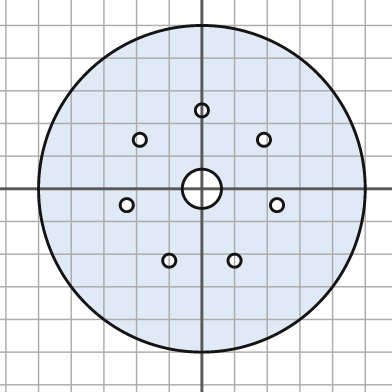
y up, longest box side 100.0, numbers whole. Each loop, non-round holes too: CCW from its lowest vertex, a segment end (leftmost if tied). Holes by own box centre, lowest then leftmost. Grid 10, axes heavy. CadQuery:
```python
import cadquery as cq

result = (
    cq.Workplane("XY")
    .moveTo(0.0, 0.0)
    .circle(50.0)
    .moveTo(-10.0, -22.0)
    .circle(2.0)
    .moveTo(10.0, -22.0)
    .circle(2.0)
    .moveTo(-23.0, -5.0)
    .circle(2.0)
    .moveTo(23.0, -5.0)
    .circle(2.0)
    .moveTo(0.0, 0.0)
    .circle(6.0)
    .moveTo(-19.0, 15.0)
    .circle(2.0)
    .moveTo(19.0, 15.0)
    .circle(2.0)
    .moveTo(0.0, 24.0)
    .circle(2.0)
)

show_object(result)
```